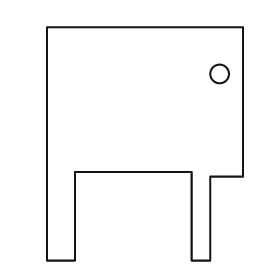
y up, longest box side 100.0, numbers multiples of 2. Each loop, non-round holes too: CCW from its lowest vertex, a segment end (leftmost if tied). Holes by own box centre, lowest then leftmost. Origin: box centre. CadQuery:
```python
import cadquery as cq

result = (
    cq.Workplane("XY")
    .moveTo(-42.0, -50.0)
    .lineTo(-30.0, -50.0)
    .lineTo(-30.0, -12.0)
    .lineTo(20.0, -12.0)
    .lineTo(20.0, -50.0)
    .lineTo(28.0, -50.0)
    .lineTo(28.0, -14.0)
    .lineTo(42.0, -14.0)
    .lineTo(42.0, 50.0)
    .lineTo(-42.0, 50.0)
    .close()
    .moveTo(32.0, 30.0)
    .circle(4.0)
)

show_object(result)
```